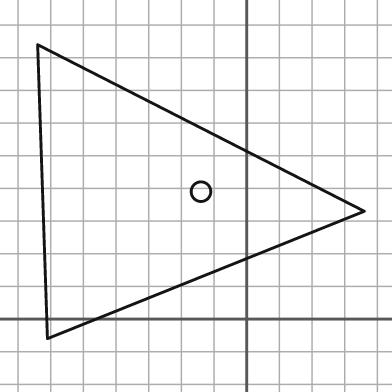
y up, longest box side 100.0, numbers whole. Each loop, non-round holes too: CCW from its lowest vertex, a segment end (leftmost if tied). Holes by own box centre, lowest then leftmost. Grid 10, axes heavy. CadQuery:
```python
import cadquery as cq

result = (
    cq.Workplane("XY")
    .moveTo(-61.0, -6.0)
    .lineTo(36.0, 33.0)
    .lineTo(-64.0, 84.0)
    .close()
    .moveTo(-14.0, 39.0)
    .circle(3.0)
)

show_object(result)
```